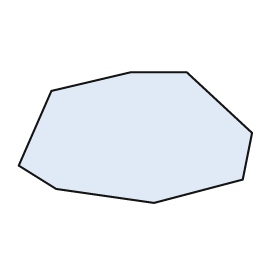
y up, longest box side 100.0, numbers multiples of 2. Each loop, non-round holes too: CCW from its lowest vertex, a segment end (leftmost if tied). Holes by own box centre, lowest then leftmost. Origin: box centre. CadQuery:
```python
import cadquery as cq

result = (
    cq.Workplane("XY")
    .moveTo(8.0, -28.0)
    .lineTo(46.0, -18.0)
    .lineTo(50.0, 2.0)
    .lineTo(22.0, 28.0)
    .lineTo(-2.0, 28.0)
    .lineTo(-36.0, 20.0)
    .lineTo(-50.0, -12.0)
    .lineTo(-34.0, -22.0)
    .close()
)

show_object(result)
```